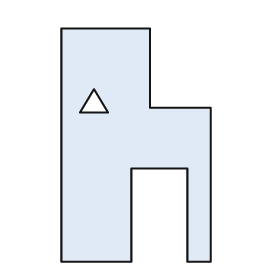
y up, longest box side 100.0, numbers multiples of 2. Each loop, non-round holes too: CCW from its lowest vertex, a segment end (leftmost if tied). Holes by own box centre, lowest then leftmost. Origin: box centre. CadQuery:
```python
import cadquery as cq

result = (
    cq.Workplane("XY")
    .moveTo(-32.0, -50.0)
    .lineTo(-2.0, -50.0)
    .lineTo(-2.0, -10.0)
    .lineTo(22.0, -10.0)
    .lineTo(22.0, -50.0)
    .lineTo(32.0, -50.0)
    .lineTo(32.0, 16.0)
    .lineTo(6.0, 16.0)
    .lineTo(6.0, 50.0)
    .lineTo(-32.0, 50.0)
    .close()
    .moveTo(-24.0, 14.0)
    .lineTo(-12.0, 14.0)
    .lineTo(-18.0, 24.0)
    .close()
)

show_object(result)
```